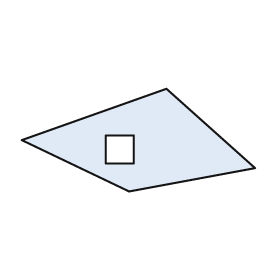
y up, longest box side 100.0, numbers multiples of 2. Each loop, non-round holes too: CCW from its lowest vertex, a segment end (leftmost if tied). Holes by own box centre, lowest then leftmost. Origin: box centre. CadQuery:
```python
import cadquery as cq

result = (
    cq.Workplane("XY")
    .moveTo(-4.0, -22.0)
    .lineTo(50.0, -12.0)
    .lineTo(12.0, 22.0)
    .lineTo(-50.0, 0.0)
    .close()
    .moveTo(-14.0, -10.0)
    .lineTo(-2.0, -10.0)
    .lineTo(-2.0, 2.0)
    .lineTo(-14.0, 2.0)
    .close()
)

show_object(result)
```